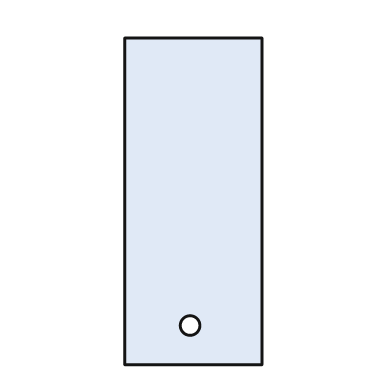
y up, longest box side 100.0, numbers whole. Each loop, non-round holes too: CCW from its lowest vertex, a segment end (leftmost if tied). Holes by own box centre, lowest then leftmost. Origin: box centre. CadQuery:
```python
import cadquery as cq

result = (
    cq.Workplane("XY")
    .moveTo(-21.0, -50.0)
    .lineTo(21.0, -50.0)
    .lineTo(21.0, 50.0)
    .lineTo(-21.0, 50.0)
    .close()
    .moveTo(-1.0, -38.0)
    .circle(3.0)
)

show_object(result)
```